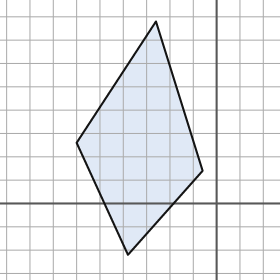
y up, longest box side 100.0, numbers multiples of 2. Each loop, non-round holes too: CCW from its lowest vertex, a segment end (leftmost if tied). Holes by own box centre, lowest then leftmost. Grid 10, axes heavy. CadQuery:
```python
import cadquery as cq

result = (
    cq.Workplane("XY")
    .moveTo(-38.0, -22.0)
    .lineTo(-6.0, 14.0)
    .lineTo(-26.0, 78.0)
    .lineTo(-60.0, 26.0)
    .close()
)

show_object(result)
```